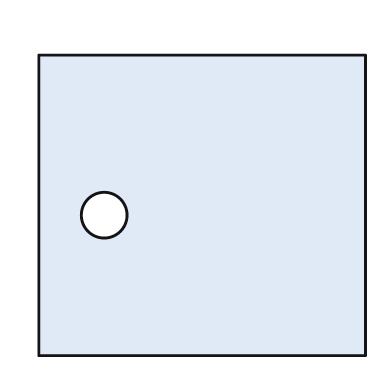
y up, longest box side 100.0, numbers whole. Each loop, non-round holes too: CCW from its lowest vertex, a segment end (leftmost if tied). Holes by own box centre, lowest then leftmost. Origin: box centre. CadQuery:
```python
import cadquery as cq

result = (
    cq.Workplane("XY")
    .moveTo(-50.0, -46.0)
    .lineTo(50.0, -46.0)
    .lineTo(50.0, 46.0)
    .lineTo(-50.0, 46.0)
    .close()
    .moveTo(-30.0, -3.0)
    .circle(7.0)
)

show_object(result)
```